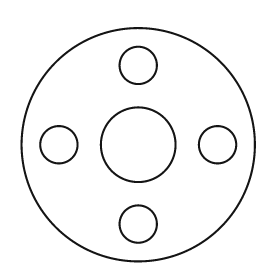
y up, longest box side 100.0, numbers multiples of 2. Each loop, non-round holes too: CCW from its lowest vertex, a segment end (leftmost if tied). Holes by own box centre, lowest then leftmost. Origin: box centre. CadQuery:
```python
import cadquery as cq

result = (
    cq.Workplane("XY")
    .moveTo(0.0, 0.0)
    .circle(50.0)
    .moveTo(0.0, -34.0)
    .circle(8.0)
    .moveTo(-34.0, 0.0)
    .circle(8.0)
    .moveTo(0.0, 0.0)
    .circle(16.0)
    .moveTo(34.0, 0.0)
    .circle(8.0)
    .moveTo(0.0, 34.0)
    .circle(8.0)
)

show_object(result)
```